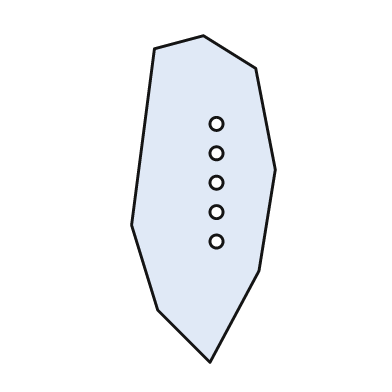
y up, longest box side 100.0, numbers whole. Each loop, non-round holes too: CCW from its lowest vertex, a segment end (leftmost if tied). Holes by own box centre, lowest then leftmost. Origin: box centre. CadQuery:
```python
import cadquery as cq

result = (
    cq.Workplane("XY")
    .moveTo(2.0, -50.0)
    .lineTo(17.0, -22.0)
    .lineTo(22.0, 9.0)
    .lineTo(16.0, 40.0)
    .lineTo(0.0, 50.0)
    .lineTo(-15.0, 46.0)
    .lineTo(-22.0, -8.0)
    .lineTo(-14.0, -34.0)
    .close()
    .moveTo(4.0, -13.0)
    .circle(2.0)
    .moveTo(4.0, -4.0)
    .circle(2.0)
    .moveTo(4.0, 5.0)
    .circle(2.0)
    .moveTo(4.0, 14.0)
    .circle(2.0)
    .moveTo(4.0, 23.0)
    .circle(2.0)
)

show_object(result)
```